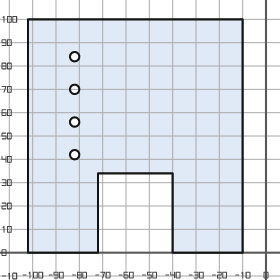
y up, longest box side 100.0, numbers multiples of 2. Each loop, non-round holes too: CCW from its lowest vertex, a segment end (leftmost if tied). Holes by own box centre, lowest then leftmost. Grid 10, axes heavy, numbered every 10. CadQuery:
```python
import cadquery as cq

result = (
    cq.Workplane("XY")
    .moveTo(-102.0, 0.0)
    .lineTo(-72.0, 0.0)
    .lineTo(-72.0, 34.0)
    .lineTo(-40.0, 34.0)
    .lineTo(-40.0, 0.0)
    .lineTo(-10.0, 0.0)
    .lineTo(-10.0, 100.0)
    .lineTo(-102.0, 100.0)
    .close()
    .moveTo(-82.0, 42.0)
    .circle(2.0)
    .moveTo(-82.0, 56.0)
    .circle(2.0)
    .moveTo(-82.0, 70.0)
    .circle(2.0)
    .moveTo(-82.0, 84.0)
    .circle(2.0)
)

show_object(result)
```